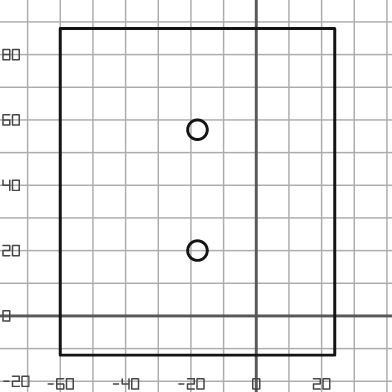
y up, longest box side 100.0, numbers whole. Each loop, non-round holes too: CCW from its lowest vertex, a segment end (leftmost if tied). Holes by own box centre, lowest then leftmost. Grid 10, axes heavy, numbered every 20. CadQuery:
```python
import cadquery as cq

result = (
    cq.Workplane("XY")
    .moveTo(-60.0, -12.0)
    .lineTo(24.0, -12.0)
    .lineTo(24.0, 88.0)
    .lineTo(-60.0, 88.0)
    .close()
    .moveTo(-18.0, 20.0)
    .circle(3.0)
    .moveTo(-18.0, 57.0)
    .circle(3.0)
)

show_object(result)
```